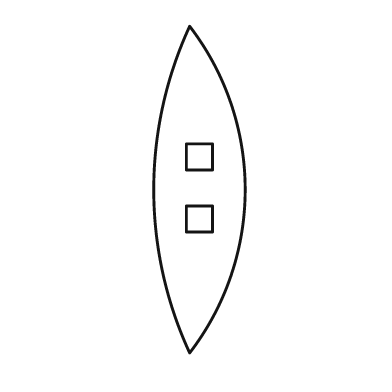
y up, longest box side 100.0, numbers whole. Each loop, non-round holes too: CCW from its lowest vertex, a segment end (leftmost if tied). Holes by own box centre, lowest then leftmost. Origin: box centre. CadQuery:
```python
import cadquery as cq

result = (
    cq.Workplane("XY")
    .moveTo(-3.0, -50.0)
    .threePointArc((14.0, 0.0), (-3.0, 50.0))
    .threePointArc((-14.0, 0.0), (-3.0, -50.0))
    .close()
    .moveTo(-4.0, -13.0)
    .lineTo(4.0, -13.0)
    .lineTo(4.0, -5.0)
    .lineTo(-4.0, -5.0)
    .close()
    .moveTo(-4.0, 6.0)
    .lineTo(4.0, 6.0)
    .lineTo(4.0, 14.0)
    .lineTo(-4.0, 14.0)
    .close()
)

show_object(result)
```